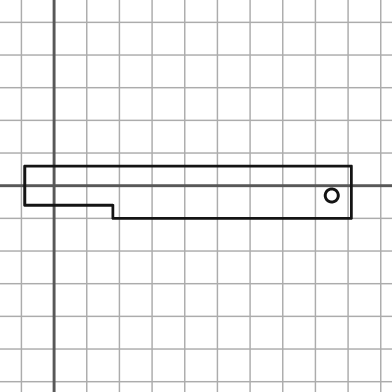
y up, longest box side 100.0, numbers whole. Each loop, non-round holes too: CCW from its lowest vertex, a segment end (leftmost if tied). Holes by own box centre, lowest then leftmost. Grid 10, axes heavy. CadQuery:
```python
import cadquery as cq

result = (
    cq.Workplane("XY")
    .moveTo(18.0, -10.0)
    .lineTo(91.0, -10.0)
    .lineTo(91.0, 6.0)
    .lineTo(-9.0, 6.0)
    .lineTo(-9.0, -6.0)
    .lineTo(18.0, -6.0)
    .close()
    .moveTo(85.0, -3.0)
    .circle(2.0)
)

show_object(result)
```